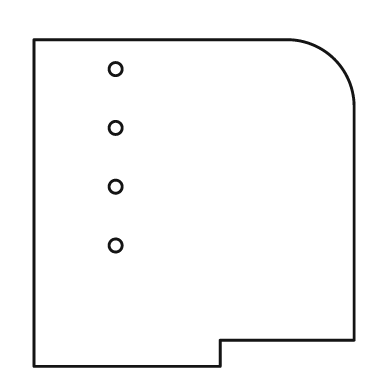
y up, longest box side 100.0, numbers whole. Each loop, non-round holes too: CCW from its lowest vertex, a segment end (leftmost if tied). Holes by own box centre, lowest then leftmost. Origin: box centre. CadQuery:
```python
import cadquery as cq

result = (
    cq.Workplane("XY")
    .moveTo(-49.0, -50.0)
    .lineTo(8.0, -50.0)
    .lineTo(8.0, -42.0)
    .lineTo(49.0, -42.0)
    .lineTo(49.0, 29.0)
    .threePointArc((43.0, 44.0), (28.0, 50.0))
    .lineTo(-49.0, 50.0)
    .close()
    .moveTo(-24.0, -13.0)
    .circle(2.0)
    .moveTo(-24.0, 5.0)
    .circle(2.0)
    .moveTo(-24.0, 23.0)
    .circle(2.0)
    .moveTo(-24.0, 41.0)
    .circle(2.0)
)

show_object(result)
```